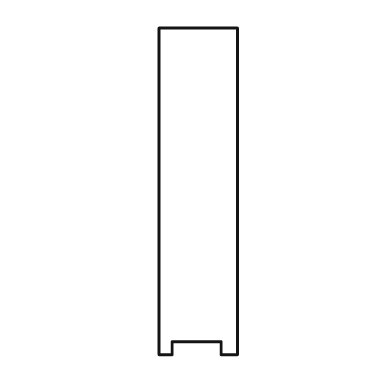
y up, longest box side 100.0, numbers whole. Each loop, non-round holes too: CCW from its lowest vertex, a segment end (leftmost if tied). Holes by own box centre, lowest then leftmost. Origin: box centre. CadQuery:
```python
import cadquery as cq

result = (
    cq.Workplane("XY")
    .moveTo(-12.0, -50.0)
    .lineTo(-8.0, -50.0)
    .lineTo(-8.0, -46.0)
    .lineTo(7.0, -46.0)
    .lineTo(7.0, -50.0)
    .lineTo(12.0, -50.0)
    .lineTo(12.0, 50.0)
    .lineTo(-12.0, 50.0)
    .close()
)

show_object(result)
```